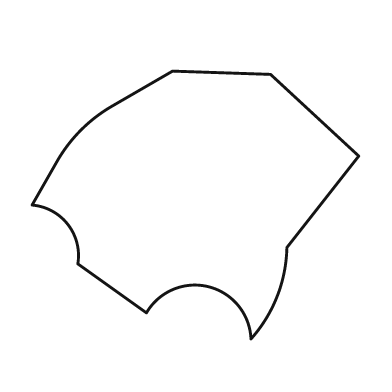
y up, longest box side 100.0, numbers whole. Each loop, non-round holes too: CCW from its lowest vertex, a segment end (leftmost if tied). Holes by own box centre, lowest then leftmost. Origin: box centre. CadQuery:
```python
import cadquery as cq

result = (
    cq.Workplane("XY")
    .moveTo(17.0, -41.0)
    .threePointArc((25.0, -28.0), (28.0, -13.0))
    .lineTo(50.0, 15.0)
    .lineTo(23.0, 40.0)
    .lineTo(-7.0, 41.0)
    .lineTo(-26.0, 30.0)
    .threePointArc((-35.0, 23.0), (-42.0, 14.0))
    .lineTo(-50.0, 0.0)
    .threePointArc((-39.0, -6.0), (-36.0, -18.0))
    .lineTo(-15.0, -33.0)
    .threePointArc((4.0, -25.0), (17.0, -41.0))
    .close()
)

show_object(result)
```